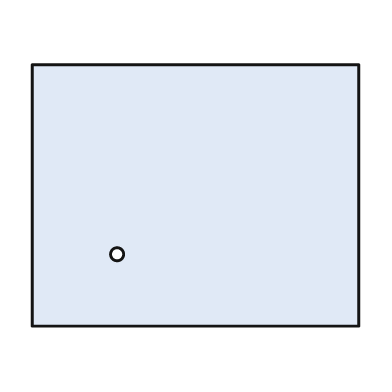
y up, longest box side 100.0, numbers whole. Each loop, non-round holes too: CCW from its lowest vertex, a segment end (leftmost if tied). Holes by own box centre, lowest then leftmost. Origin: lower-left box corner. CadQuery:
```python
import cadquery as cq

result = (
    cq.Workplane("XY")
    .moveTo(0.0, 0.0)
    .lineTo(100.0, 0.0)
    .lineTo(100.0, 80.0)
    .lineTo(0.0, 80.0)
    .close()
    .moveTo(26.0, 22.0)
    .circle(2.0)
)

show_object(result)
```